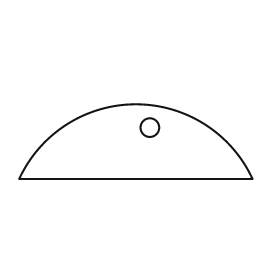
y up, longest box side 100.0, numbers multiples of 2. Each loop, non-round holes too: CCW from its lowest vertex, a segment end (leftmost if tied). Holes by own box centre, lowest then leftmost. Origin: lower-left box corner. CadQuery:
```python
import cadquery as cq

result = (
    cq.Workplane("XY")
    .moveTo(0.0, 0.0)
    .lineTo(100.0, 0.0)
    .threePointArc((50.0, 32.0), (0.0, 0.0))
    .close()
    .moveTo(56.0, 22.0)
    .circle(4.0)
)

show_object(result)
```